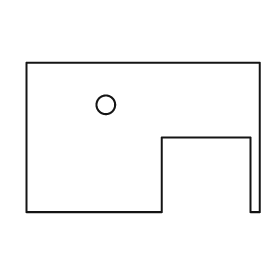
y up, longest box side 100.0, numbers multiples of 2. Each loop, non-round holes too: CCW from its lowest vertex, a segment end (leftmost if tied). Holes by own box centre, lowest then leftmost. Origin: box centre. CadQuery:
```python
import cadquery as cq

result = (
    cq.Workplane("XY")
    .moveTo(-50.0, -32.0)
    .lineTo(8.0, -32.0)
    .lineTo(8.0, 0.0)
    .lineTo(46.0, 0.0)
    .lineTo(46.0, -32.0)
    .lineTo(50.0, -32.0)
    .lineTo(50.0, 32.0)
    .lineTo(-50.0, 32.0)
    .close()
    .moveTo(-16.0, 14.0)
    .circle(4.0)
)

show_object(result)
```